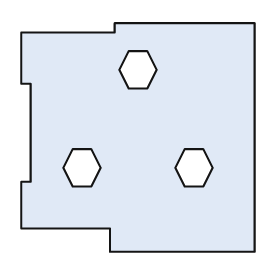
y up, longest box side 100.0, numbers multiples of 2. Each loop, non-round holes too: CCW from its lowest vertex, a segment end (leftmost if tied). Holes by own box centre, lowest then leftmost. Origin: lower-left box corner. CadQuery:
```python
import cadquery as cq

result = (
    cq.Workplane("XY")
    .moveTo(38.0, 0.0)
    .lineTo(100.0, 0.0)
    .lineTo(100.0, 98.0)
    .lineTo(40.0, 98.0)
    .lineTo(40.0, 94.0)
    .lineTo(0.0, 94.0)
    .lineTo(0.0, 72.0)
    .lineTo(4.0, 72.0)
    .lineTo(4.0, 30.0)
    .lineTo(0.0, 30.0)
    .lineTo(0.0, 10.0)
    .lineTo(38.0, 10.0)
    .close()
    .moveTo(22.0, 28.0)
    .lineTo(30.0, 28.0)
    .lineTo(34.0, 36.0)
    .lineTo(30.0, 44.0)
    .lineTo(22.0, 44.0)
    .lineTo(18.0, 36.0)
    .close()
    .moveTo(70.0, 28.0)
    .lineTo(78.0, 28.0)
    .lineTo(82.0, 36.0)
    .lineTo(78.0, 44.0)
    .lineTo(70.0, 44.0)
    .lineTo(66.0, 36.0)
    .close()
    .moveTo(46.0, 70.0)
    .lineTo(54.0, 70.0)
    .lineTo(58.0, 78.0)
    .lineTo(54.0, 86.0)
    .lineTo(46.0, 86.0)
    .lineTo(42.0, 78.0)
    .close()
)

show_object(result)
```